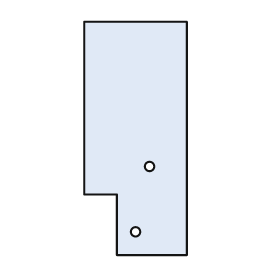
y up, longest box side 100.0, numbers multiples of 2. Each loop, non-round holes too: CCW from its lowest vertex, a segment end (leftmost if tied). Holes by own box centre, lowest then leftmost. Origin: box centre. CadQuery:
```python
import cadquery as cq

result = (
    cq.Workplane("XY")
    .moveTo(-8.0, -50.0)
    .lineTo(22.0, -50.0)
    .lineTo(22.0, 50.0)
    .lineTo(-22.0, 50.0)
    .lineTo(-22.0, -24.0)
    .lineTo(-8.0, -24.0)
    .close()
    .moveTo(0.0, -40.0)
    .circle(2.0)
    .moveTo(6.0, -12.0)
    .circle(2.0)
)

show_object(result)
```